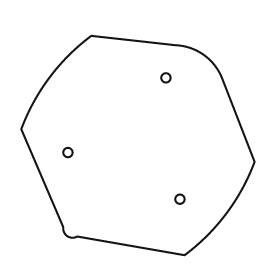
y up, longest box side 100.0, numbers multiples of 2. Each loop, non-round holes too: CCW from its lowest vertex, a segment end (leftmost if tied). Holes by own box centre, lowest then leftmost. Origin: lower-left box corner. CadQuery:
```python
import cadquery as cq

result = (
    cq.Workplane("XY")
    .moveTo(70.0, 0.0)
    .threePointArc((88.0, 18.0), (100.0, 40.0))
    .lineTo(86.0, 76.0)
    .threePointArc((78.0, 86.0), (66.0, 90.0))
    .lineTo(30.0, 94.0)
    .threePointArc((12.0, 76.0), (0.0, 54.0))
    .lineTo(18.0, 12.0)
    .threePointArc((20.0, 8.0), (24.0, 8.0))
    .close()
    .moveTo(68.0, 24.0)
    .circle(2.0)
    .moveTo(20.0, 44.0)
    .circle(2.0)
    .moveTo(62.0, 76.0)
    .circle(2.0)
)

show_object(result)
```